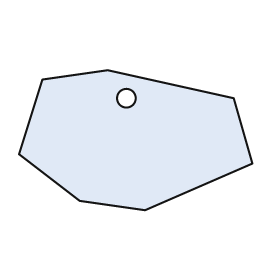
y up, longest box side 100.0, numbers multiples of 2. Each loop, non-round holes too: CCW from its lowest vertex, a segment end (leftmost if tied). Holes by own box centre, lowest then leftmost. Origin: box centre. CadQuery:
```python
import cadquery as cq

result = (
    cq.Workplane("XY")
    .moveTo(4.0, -30.0)
    .lineTo(50.0, -10.0)
    .lineTo(42.0, 18.0)
    .lineTo(-12.0, 30.0)
    .lineTo(-40.0, 26.0)
    .lineTo(-50.0, -6.0)
    .lineTo(-24.0, -26.0)
    .close()
    .moveTo(-4.0, 18.0)
    .circle(4.0)
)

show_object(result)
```